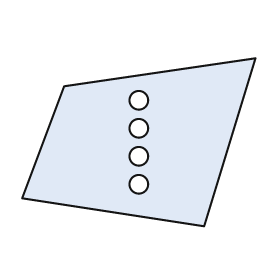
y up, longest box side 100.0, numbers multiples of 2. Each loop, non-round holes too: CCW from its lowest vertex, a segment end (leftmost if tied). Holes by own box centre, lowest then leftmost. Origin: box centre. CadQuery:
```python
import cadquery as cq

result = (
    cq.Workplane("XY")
    .moveTo(28.0, -36.0)
    .lineTo(50.0, 36.0)
    .lineTo(-32.0, 24.0)
    .lineTo(-50.0, -24.0)
    .close()
    .moveTo(0.0, -18.0)
    .circle(4.0)
    .moveTo(0.0, -6.0)
    .circle(4.0)
    .moveTo(0.0, 6.0)
    .circle(4.0)
    .moveTo(0.0, 18.0)
    .circle(4.0)
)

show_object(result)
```